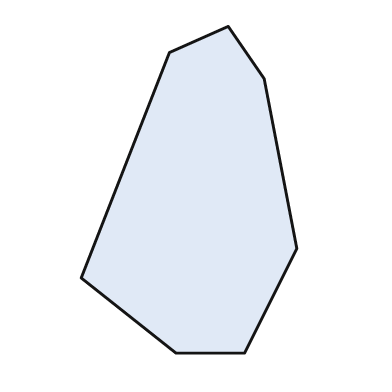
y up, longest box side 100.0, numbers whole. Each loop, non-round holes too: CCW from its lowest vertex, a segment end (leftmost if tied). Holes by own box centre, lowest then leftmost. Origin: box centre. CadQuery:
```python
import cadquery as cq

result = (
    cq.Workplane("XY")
    .moveTo(-4.0, -50.0)
    .lineTo(17.0, -50.0)
    .lineTo(33.0, -18.0)
    .lineTo(23.0, 34.0)
    .lineTo(12.0, 50.0)
    .lineTo(-6.0, 42.0)
    .lineTo(-33.0, -27.0)
    .close()
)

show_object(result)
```